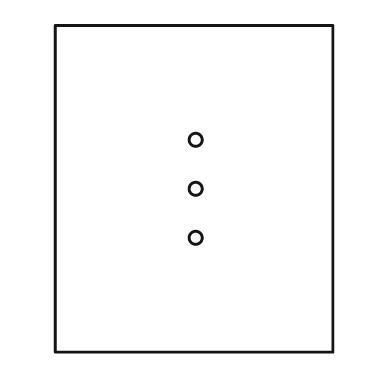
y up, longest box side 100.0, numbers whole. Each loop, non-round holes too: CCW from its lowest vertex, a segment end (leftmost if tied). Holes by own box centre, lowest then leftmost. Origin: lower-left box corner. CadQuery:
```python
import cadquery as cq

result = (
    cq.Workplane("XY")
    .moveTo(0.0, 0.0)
    .lineTo(85.0, 0.0)
    .lineTo(85.0, 100.0)
    .lineTo(0.0, 100.0)
    .close()
    .moveTo(43.0, 35.0)
    .circle(2.0)
    .moveTo(43.0, 50.0)
    .circle(2.0)
    .moveTo(43.0, 65.0)
    .circle(2.0)
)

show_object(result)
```